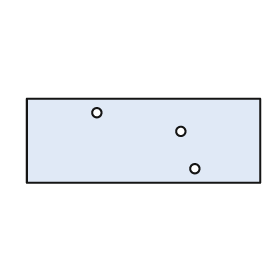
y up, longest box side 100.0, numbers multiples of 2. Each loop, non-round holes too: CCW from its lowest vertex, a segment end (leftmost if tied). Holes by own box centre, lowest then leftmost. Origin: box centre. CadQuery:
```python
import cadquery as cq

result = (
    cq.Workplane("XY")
    .moveTo(-50.0, -18.0)
    .lineTo(50.0, -18.0)
    .lineTo(50.0, 18.0)
    .lineTo(-50.0, 18.0)
    .close()
    .moveTo(22.0, -12.0)
    .circle(2.0)
    .moveTo(16.0, 4.0)
    .circle(2.0)
    .moveTo(-20.0, 12.0)
    .circle(2.0)
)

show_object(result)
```